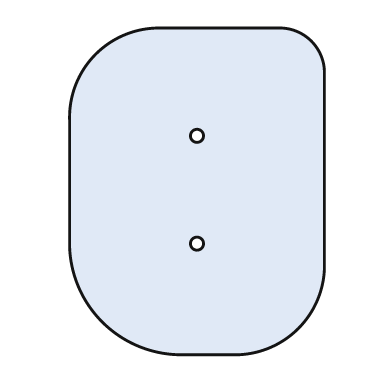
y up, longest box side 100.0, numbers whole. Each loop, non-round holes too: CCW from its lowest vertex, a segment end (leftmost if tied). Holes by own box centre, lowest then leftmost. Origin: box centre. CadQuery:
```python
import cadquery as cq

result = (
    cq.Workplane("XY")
    .moveTo(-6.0, -50.0)
    .lineTo(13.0, -50.0)
    .threePointArc((31.0, -42.0), (39.0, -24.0))
    .lineTo(39.0, 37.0)
    .threePointArc((35.0, 46.0), (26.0, 50.0))
    .lineTo(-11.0, 50.0)
    .threePointArc((-31.0, 42.0), (-39.0, 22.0))
    .lineTo(-39.0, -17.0)
    .threePointArc((-29.0, -40.0), (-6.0, -50.0))
    .close()
    .moveTo(0.0, -16.0)
    .circle(2.0)
    .moveTo(0.0, 17.0)
    .circle(2.0)
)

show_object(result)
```